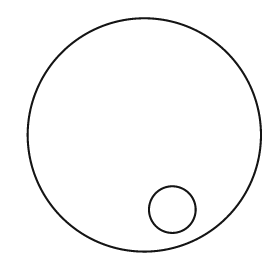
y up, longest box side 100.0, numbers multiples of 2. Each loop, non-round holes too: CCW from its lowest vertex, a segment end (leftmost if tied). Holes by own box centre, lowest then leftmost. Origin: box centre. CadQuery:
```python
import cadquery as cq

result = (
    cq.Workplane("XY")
    .moveTo(0.0, 0.0)
    .circle(50.0)
    .moveTo(12.0, -32.0)
    .circle(10.0)
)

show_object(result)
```